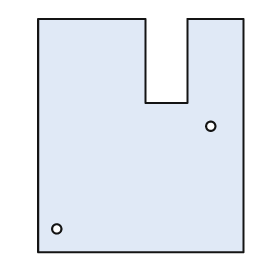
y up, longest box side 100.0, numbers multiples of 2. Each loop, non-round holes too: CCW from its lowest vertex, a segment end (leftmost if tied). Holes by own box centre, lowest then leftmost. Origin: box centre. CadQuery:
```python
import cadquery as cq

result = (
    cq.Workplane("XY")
    .moveTo(-44.0, -50.0)
    .lineTo(44.0, -50.0)
    .lineTo(44.0, 50.0)
    .lineTo(20.0, 50.0)
    .lineTo(20.0, 14.0)
    .lineTo(2.0, 14.0)
    .lineTo(2.0, 50.0)
    .lineTo(-44.0, 50.0)
    .close()
    .moveTo(-36.0, -40.0)
    .circle(2.0)
    .moveTo(30.0, 4.0)
    .circle(2.0)
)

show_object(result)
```